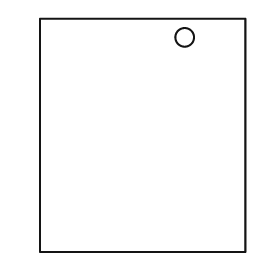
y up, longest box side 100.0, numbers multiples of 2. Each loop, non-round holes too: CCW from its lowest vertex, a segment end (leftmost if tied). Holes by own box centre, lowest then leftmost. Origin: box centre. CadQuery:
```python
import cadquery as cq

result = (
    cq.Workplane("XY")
    .moveTo(-44.0, -50.0)
    .lineTo(44.0, -50.0)
    .lineTo(44.0, 50.0)
    .lineTo(-44.0, 50.0)
    .close()
    .moveTo(18.0, 42.0)
    .circle(4.0)
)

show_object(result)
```